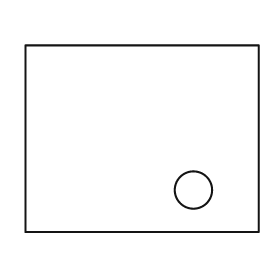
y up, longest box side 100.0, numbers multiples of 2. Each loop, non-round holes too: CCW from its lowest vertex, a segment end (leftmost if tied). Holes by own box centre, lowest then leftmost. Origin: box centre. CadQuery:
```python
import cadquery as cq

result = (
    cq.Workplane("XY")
    .moveTo(-50.0, -40.0)
    .lineTo(50.0, -40.0)
    .lineTo(50.0, 40.0)
    .lineTo(-50.0, 40.0)
    .close()
    .moveTo(22.0, -22.0)
    .circle(8.0)
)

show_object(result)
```